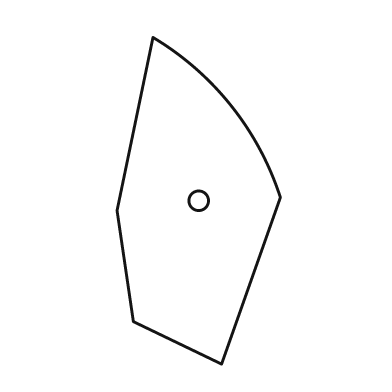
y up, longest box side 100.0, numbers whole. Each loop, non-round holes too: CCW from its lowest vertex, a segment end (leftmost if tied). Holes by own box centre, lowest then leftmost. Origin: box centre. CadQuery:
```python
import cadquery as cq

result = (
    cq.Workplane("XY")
    .moveTo(7.0, -50.0)
    .lineTo(25.0, 1.0)
    .threePointArc((10.0, 29.0), (-14.0, 50.0))
    .lineTo(-25.0, -3.0)
    .lineTo(-20.0, -37.0)
    .close()
    .moveTo(0.0, 0.0)
    .circle(3.0)
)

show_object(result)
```